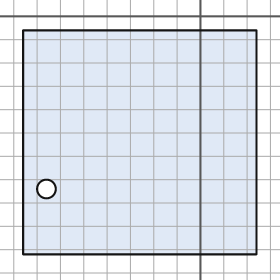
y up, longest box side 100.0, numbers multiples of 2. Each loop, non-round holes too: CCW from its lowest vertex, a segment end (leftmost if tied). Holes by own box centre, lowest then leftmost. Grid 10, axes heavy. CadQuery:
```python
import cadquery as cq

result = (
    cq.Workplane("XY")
    .moveTo(-76.0, -102.0)
    .lineTo(24.0, -102.0)
    .lineTo(24.0, -6.0)
    .lineTo(-76.0, -6.0)
    .close()
    .moveTo(-66.0, -74.0)
    .circle(4.0)
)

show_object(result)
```